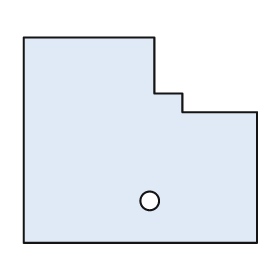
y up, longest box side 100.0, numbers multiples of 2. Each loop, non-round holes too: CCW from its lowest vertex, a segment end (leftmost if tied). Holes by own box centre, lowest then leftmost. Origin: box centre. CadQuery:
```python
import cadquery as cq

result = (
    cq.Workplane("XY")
    .moveTo(-50.0, -44.0)
    .lineTo(50.0, -44.0)
    .lineTo(50.0, 12.0)
    .lineTo(18.0, 12.0)
    .lineTo(18.0, 20.0)
    .lineTo(6.0, 20.0)
    .lineTo(6.0, 44.0)
    .lineTo(-50.0, 44.0)
    .close()
    .moveTo(4.0, -26.0)
    .circle(4.0)
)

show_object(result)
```